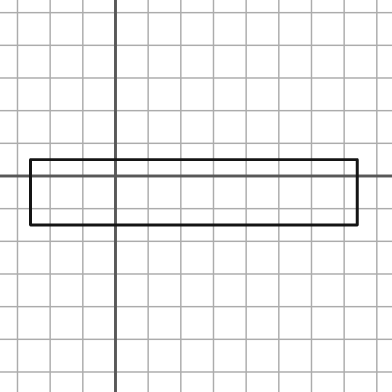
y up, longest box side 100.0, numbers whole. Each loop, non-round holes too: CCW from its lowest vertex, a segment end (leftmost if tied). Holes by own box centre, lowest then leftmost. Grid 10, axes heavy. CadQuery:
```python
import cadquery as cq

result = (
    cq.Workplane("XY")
    .moveTo(-26.0, -15.0)
    .lineTo(74.0, -15.0)
    .lineTo(74.0, 5.0)
    .lineTo(-26.0, 5.0)
    .close()
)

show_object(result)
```